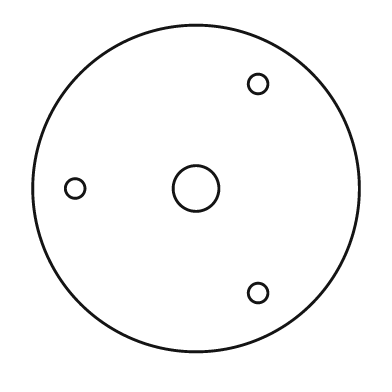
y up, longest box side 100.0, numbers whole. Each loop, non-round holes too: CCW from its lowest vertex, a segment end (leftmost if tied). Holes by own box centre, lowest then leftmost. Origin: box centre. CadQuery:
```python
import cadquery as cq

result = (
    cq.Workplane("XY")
    .moveTo(0.0, 0.0)
    .circle(50.0)
    .moveTo(19.0, -32.0)
    .circle(3.0)
    .moveTo(-37.0, 0.0)
    .circle(3.0)
    .moveTo(0.0, 0.0)
    .circle(7.0)
    .moveTo(19.0, 32.0)
    .circle(3.0)
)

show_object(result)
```